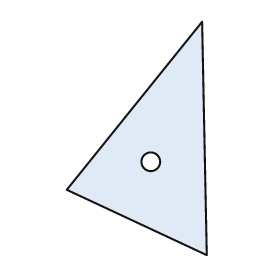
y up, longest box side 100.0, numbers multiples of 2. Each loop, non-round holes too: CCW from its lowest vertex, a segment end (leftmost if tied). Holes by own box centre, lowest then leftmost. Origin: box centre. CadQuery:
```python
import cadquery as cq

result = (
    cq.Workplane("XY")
    .moveTo(30.0, -50.0)
    .lineTo(28.0, 50.0)
    .lineTo(-30.0, -22.0)
    .close()
    .moveTo(6.0, -10.0)
    .circle(4.0)
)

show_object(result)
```